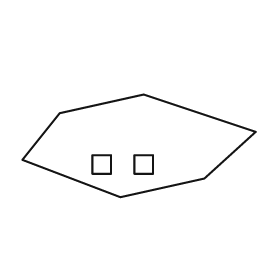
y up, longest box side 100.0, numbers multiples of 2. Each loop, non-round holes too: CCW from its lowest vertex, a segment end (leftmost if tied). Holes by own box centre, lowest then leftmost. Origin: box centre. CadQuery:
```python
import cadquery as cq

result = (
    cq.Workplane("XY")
    .moveTo(-8.0, -22.0)
    .lineTo(28.0, -14.0)
    .lineTo(50.0, 6.0)
    .lineTo(2.0, 22.0)
    .lineTo(-34.0, 14.0)
    .lineTo(-50.0, -6.0)
    .close()
    .moveTo(-20.0, -12.0)
    .lineTo(-12.0, -12.0)
    .lineTo(-12.0, -4.0)
    .lineTo(-20.0, -4.0)
    .close()
    .moveTo(-2.0, -12.0)
    .lineTo(6.0, -12.0)
    .lineTo(6.0, -4.0)
    .lineTo(-2.0, -4.0)
    .close()
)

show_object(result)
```